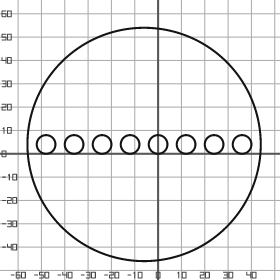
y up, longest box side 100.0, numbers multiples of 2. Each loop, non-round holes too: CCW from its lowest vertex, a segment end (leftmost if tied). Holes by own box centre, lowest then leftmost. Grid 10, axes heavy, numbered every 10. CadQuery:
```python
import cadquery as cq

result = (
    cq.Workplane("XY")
    .moveTo(-6.0, 4.0)
    .circle(50.0)
    .moveTo(-48.0, 4.0)
    .circle(4.0)
    .moveTo(-36.0, 4.0)
    .circle(4.0)
    .moveTo(-24.0, 4.0)
    .circle(4.0)
    .moveTo(-12.0, 4.0)
    .circle(4.0)
    .moveTo(0.0, 4.0)
    .circle(4.0)
    .moveTo(12.0, 4.0)
    .circle(4.0)
    .moveTo(24.0, 4.0)
    .circle(4.0)
    .moveTo(36.0, 4.0)
    .circle(4.0)
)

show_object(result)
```